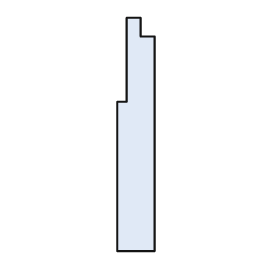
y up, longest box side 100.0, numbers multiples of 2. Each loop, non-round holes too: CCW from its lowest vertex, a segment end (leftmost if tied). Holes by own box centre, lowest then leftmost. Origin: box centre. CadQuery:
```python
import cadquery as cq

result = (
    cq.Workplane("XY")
    .moveTo(-8.0, -50.0)
    .lineTo(8.0, -50.0)
    .lineTo(8.0, 42.0)
    .lineTo(2.0, 42.0)
    .lineTo(2.0, 50.0)
    .lineTo(-4.0, 50.0)
    .lineTo(-4.0, 14.0)
    .lineTo(-8.0, 14.0)
    .close()
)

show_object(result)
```